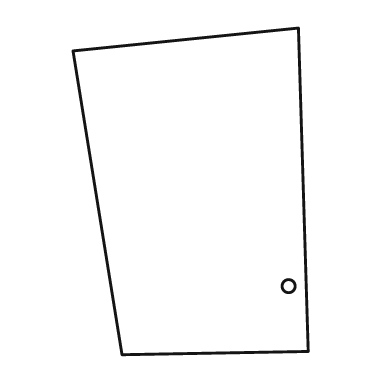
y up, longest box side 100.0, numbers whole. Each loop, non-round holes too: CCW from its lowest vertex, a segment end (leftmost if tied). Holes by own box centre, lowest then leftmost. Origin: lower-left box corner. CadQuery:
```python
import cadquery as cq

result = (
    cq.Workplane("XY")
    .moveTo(15.0, 0.0)
    .lineTo(72.0, 1.0)
    .lineTo(69.0, 100.0)
    .lineTo(0.0, 93.0)
    .close()
    .moveTo(66.0, 21.0)
    .circle(2.0)
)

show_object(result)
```